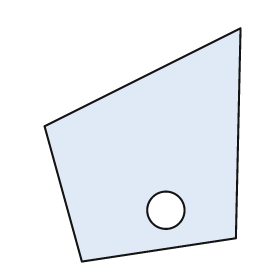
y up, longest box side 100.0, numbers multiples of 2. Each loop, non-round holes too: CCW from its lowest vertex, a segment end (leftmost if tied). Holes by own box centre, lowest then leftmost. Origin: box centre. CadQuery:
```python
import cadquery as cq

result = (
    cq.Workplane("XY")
    .moveTo(-26.0, -50.0)
    .lineTo(40.0, -40.0)
    .lineTo(42.0, 50.0)
    .lineTo(-42.0, 8.0)
    .close()
    .moveTo(10.0, -28.0)
    .circle(8.0)
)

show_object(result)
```